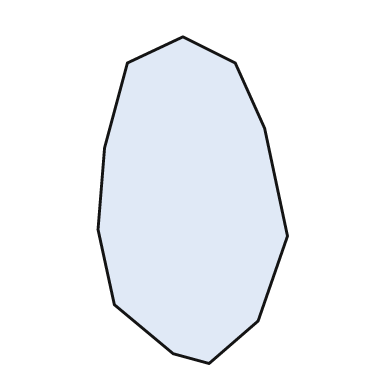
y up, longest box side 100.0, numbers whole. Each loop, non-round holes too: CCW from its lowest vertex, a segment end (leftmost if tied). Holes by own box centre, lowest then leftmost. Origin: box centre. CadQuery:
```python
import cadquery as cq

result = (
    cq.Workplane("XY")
    .moveTo(5.0, -50.0)
    .lineTo(20.0, -37.0)
    .lineTo(29.0, -11.0)
    .lineTo(22.0, 22.0)
    .lineTo(13.0, 42.0)
    .lineTo(-3.0, 50.0)
    .lineTo(-20.0, 42.0)
    .lineTo(-27.0, 16.0)
    .lineTo(-29.0, -9.0)
    .lineTo(-24.0, -32.0)
    .lineTo(-6.0, -47.0)
    .close()
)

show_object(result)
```